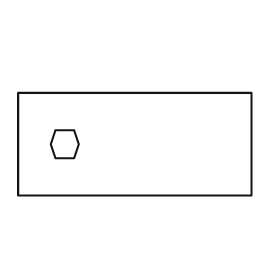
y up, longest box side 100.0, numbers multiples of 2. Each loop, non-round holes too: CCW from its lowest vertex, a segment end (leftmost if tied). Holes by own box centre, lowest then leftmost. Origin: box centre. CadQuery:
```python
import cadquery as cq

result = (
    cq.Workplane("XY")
    .moveTo(-50.0, -22.0)
    .lineTo(50.0, -22.0)
    .lineTo(50.0, 22.0)
    .lineTo(-50.0, 22.0)
    .close()
    .moveTo(-34.0, -6.0)
    .lineTo(-26.0, -6.0)
    .lineTo(-24.0, 0.0)
    .lineTo(-26.0, 6.0)
    .lineTo(-34.0, 6.0)
    .lineTo(-36.0, 0.0)
    .close()
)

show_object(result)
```